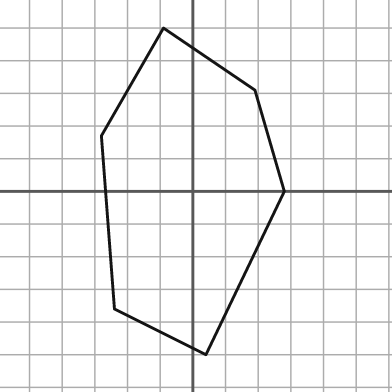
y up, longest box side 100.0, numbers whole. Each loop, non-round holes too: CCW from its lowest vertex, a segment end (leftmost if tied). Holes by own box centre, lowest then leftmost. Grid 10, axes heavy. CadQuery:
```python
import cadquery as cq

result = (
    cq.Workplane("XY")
    .moveTo(4.0, -50.0)
    .lineTo(28.0, 0.0)
    .lineTo(19.0, 31.0)
    .lineTo(-9.0, 50.0)
    .lineTo(-28.0, 17.0)
    .lineTo(-24.0, -36.0)
    .close()
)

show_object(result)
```